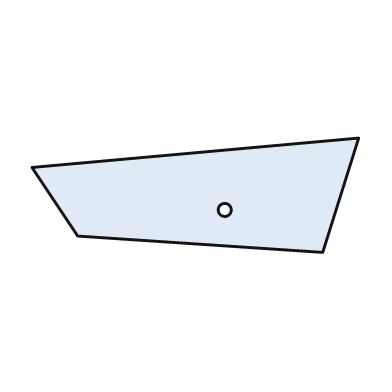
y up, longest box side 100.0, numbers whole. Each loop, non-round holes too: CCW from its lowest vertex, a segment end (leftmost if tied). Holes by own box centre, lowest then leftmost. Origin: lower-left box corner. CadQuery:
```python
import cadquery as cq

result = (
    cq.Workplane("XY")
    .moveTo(89.0, 0.0)
    .lineTo(100.0, 35.0)
    .lineTo(0.0, 26.0)
    .lineTo(14.0, 5.0)
    .close()
    .moveTo(59.0, 13.0)
    .circle(2.0)
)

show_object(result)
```